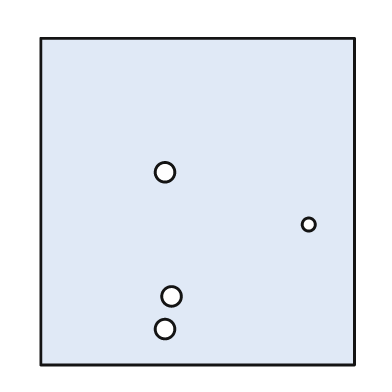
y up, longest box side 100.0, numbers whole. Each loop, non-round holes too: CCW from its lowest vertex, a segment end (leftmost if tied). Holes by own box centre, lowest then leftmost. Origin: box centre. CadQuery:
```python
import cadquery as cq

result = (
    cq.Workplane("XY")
    .moveTo(-48.0, -50.0)
    .lineTo(48.0, -50.0)
    .lineTo(48.0, 50.0)
    .lineTo(-48.0, 50.0)
    .close()
    .moveTo(-10.0, -39.0)
    .circle(3.0)
    .moveTo(-8.0, -29.0)
    .circle(3.0)
    .moveTo(34.0, -7.0)
    .circle(2.0)
    .moveTo(-10.0, 9.0)
    .circle(3.0)
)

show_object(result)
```